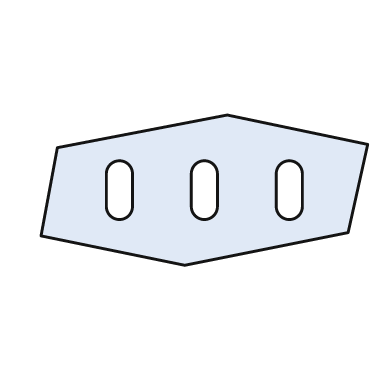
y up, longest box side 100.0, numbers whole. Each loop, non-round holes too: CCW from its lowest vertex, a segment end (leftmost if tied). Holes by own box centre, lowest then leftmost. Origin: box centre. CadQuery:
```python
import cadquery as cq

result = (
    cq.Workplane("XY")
    .moveTo(-6.0, -23.0)
    .lineTo(44.0, -13.0)
    .lineTo(50.0, 14.0)
    .lineTo(7.0, 23.0)
    .lineTo(-45.0, 13.0)
    .lineTo(-50.0, -14.0)
    .close()
    .moveTo(-30.0, -5.0)
    .threePointArc((-26.0, -9.0), (-22.0, -5.0))
    .lineTo(-22.0, 5.0)
    .threePointArc((-26.0, 9.0), (-30.0, 5.0))
    .close()
    .moveTo(-4.0, -5.0)
    .threePointArc((0.0, -9.0), (4.0, -5.0))
    .lineTo(4.0, 5.0)
    .threePointArc((0.0, 9.0), (-4.0, 5.0))
    .close()
    .moveTo(22.0, -5.0)
    .threePointArc((26.0, -9.0), (30.0, -5.0))
    .lineTo(30.0, 5.0)
    .threePointArc((26.0, 9.0), (22.0, 5.0))
    .close()
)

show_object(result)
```